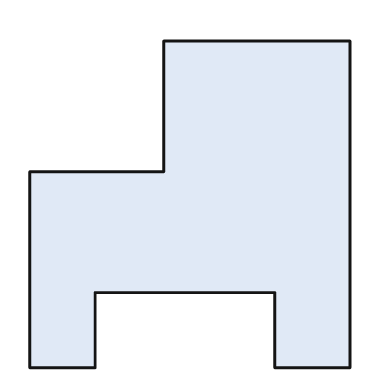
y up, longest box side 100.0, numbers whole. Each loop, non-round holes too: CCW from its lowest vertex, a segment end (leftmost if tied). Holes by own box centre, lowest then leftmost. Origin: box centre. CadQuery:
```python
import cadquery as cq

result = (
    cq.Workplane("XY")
    .moveTo(-49.0, -50.0)
    .lineTo(-29.0, -50.0)
    .lineTo(-29.0, -27.0)
    .lineTo(26.0, -27.0)
    .lineTo(26.0, -50.0)
    .lineTo(49.0, -50.0)
    .lineTo(49.0, 50.0)
    .lineTo(-8.0, 50.0)
    .lineTo(-8.0, 10.0)
    .lineTo(-49.0, 10.0)
    .close()
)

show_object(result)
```